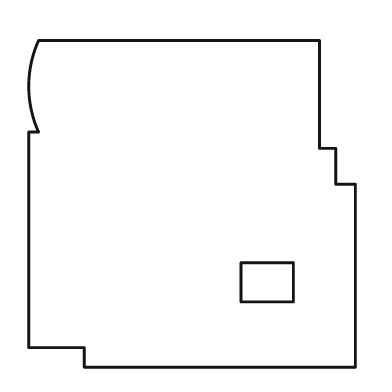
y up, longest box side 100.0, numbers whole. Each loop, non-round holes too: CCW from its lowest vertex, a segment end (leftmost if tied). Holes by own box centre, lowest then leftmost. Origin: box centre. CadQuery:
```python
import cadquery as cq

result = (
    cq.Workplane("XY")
    .moveTo(-33.0, -50.0)
    .lineTo(50.0, -50.0)
    .lineTo(50.0, 6.0)
    .lineTo(44.0, 6.0)
    .lineTo(44.0, 17.0)
    .lineTo(39.0, 17.0)
    .lineTo(39.0, 50.0)
    .lineTo(-47.0, 50.0)
    .threePointArc((-50.0, 36.0), (-47.0, 22.0))
    .lineTo(-50.0, 22.0)
    .lineTo(-50.0, -44.0)
    .lineTo(-33.0, -44.0)
    .close()
    .moveTo(15.0, -30.0)
    .lineTo(31.0, -30.0)
    .lineTo(31.0, -18.0)
    .lineTo(15.0, -18.0)
    .close()
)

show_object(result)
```